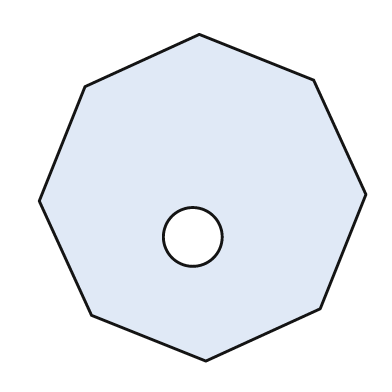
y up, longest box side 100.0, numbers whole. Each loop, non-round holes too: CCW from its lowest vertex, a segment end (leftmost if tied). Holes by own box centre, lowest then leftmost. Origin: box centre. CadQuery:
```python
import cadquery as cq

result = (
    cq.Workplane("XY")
    .moveTo(1.0, -50.0)
    .lineTo(36.0, -34.0)
    .lineTo(50.0, 1.0)
    .lineTo(34.0, 36.0)
    .lineTo(-1.0, 50.0)
    .lineTo(-36.0, 34.0)
    .lineTo(-50.0, -1.0)
    .lineTo(-34.0, -36.0)
    .close()
    .moveTo(-3.0, -12.0)
    .circle(9.0)
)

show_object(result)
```